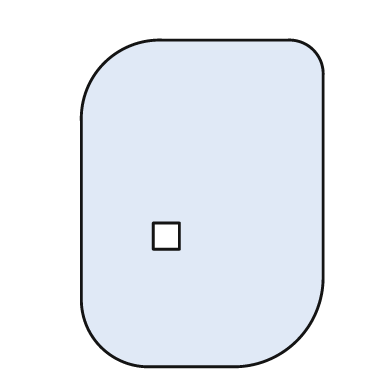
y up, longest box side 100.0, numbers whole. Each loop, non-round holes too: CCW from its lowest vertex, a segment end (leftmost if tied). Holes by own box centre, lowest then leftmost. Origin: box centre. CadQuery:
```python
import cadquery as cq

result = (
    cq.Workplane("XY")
    .moveTo(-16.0, -50.0)
    .lineTo(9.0, -50.0)
    .threePointArc((29.0, -42.0), (37.0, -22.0))
    .lineTo(37.0, 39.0)
    .threePointArc((34.0, 47.0), (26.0, 50.0))
    .lineTo(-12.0, 50.0)
    .threePointArc((-30.0, 43.0), (-37.0, 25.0))
    .lineTo(-37.0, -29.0)
    .threePointArc((-31.0, -44.0), (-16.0, -50.0))
    .close()
    .moveTo(-15.0, -14.0)
    .lineTo(-7.0, -14.0)
    .lineTo(-7.0, -6.0)
    .lineTo(-15.0, -6.0)
    .close()
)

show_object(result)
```